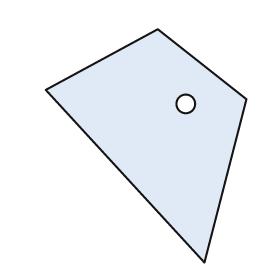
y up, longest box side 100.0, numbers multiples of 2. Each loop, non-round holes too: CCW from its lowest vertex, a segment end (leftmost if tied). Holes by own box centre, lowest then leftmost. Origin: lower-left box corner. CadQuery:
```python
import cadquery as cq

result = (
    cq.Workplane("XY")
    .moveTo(68.0, 0.0)
    .lineTo(86.0, 70.0)
    .lineTo(48.0, 100.0)
    .lineTo(0.0, 74.0)
    .close()
    .moveTo(60.0, 68.0)
    .circle(4.0)
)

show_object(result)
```